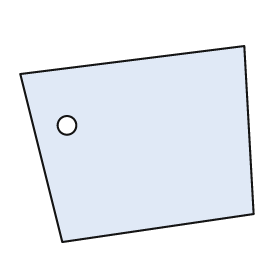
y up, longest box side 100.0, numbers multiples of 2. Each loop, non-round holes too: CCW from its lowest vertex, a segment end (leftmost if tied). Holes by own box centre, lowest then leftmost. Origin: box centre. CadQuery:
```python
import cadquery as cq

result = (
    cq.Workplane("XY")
    .moveTo(-32.0, -42.0)
    .lineTo(50.0, -30.0)
    .lineTo(46.0, 42.0)
    .lineTo(-50.0, 30.0)
    .close()
    .moveTo(-30.0, 8.0)
    .circle(4.0)
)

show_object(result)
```